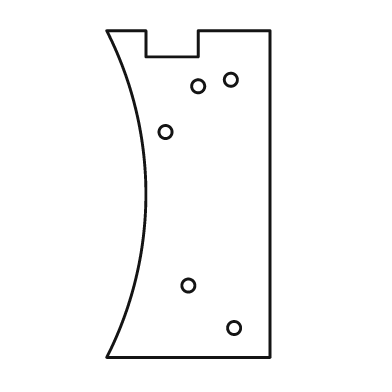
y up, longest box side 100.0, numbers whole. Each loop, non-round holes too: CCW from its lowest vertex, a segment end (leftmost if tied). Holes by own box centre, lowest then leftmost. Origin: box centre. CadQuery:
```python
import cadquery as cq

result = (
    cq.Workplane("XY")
    .moveTo(-25.0, -50.0)
    .lineTo(25.0, -50.0)
    .lineTo(25.0, 50.0)
    .lineTo(3.0, 50.0)
    .lineTo(3.0, 42.0)
    .lineTo(-13.0, 42.0)
    .lineTo(-13.0, 50.0)
    .lineTo(-25.0, 50.0)
    .threePointArc((-13.0, 0.0), (-25.0, -50.0))
    .close()
    .moveTo(14.0, -41.0)
    .circle(2.0)
    .moveTo(0.0, -28.0)
    .circle(2.0)
    .moveTo(-7.0, 19.0)
    .circle(2.0)
    .moveTo(3.0, 33.0)
    .circle(2.0)
    .moveTo(13.0, 35.0)
    .circle(2.0)
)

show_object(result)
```